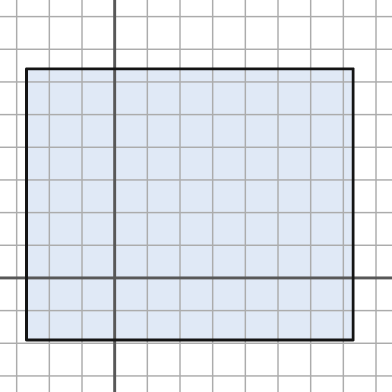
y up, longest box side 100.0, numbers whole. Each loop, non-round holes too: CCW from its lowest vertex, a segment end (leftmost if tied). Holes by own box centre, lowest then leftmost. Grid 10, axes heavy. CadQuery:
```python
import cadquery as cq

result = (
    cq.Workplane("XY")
    .moveTo(-27.0, -19.0)
    .lineTo(73.0, -19.0)
    .lineTo(73.0, 64.0)
    .lineTo(-27.0, 64.0)
    .close()
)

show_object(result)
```